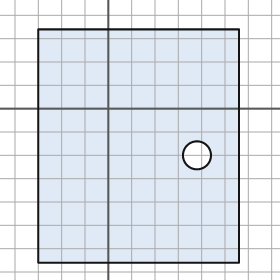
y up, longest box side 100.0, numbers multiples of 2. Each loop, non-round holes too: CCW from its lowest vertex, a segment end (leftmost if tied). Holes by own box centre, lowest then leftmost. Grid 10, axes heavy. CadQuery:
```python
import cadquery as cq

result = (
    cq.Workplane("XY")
    .moveTo(-30.0, -66.0)
    .lineTo(56.0, -66.0)
    .lineTo(56.0, 34.0)
    .lineTo(-30.0, 34.0)
    .close()
    .moveTo(38.0, -20.0)
    .circle(6.0)
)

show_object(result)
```